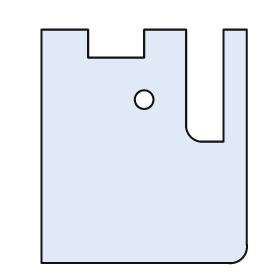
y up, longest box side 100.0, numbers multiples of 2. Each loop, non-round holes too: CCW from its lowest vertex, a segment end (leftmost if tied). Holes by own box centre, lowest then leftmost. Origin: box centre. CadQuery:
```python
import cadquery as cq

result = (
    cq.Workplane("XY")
    .moveTo(-44.0, -50.0)
    .lineTo(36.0, -50.0)
    .threePointArc((42.0, -48.0), (44.0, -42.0))
    .lineTo(44.0, 50.0)
    .lineTo(34.0, 50.0)
    .lineTo(34.0, 2.0)
    .lineTo(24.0, 2.0)
    .threePointArc((20.0, 4.0), (18.0, 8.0))
    .lineTo(18.0, 50.0)
    .lineTo(0.0, 50.0)
    .lineTo(0.0, 38.0)
    .lineTo(-24.0, 38.0)
    .lineTo(-24.0, 50.0)
    .lineTo(-44.0, 50.0)
    .close()
    .moveTo(0.0, 20.0)
    .circle(4.0)
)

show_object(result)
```